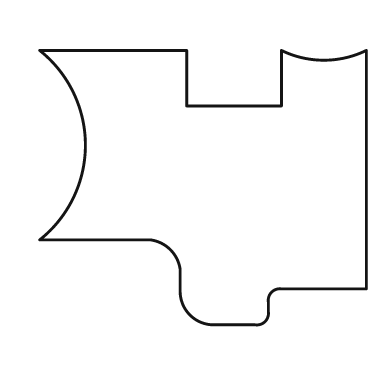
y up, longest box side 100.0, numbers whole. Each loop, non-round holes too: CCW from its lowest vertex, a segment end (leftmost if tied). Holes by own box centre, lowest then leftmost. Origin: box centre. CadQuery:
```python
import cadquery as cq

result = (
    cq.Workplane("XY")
    .moveTo(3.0, -42.0)
    .lineTo(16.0, -42.0)
    .threePointArc((19.0, -41.0), (20.0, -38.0))
    .lineTo(20.0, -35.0)
    .threePointArc((21.0, -32.0), (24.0, -31.0))
    .lineTo(50.0, -31.0)
    .lineTo(50.0, 42.0)
    .threePointArc((37.0, 39.0), (24.0, 42.0))
    .lineTo(24.0, 25.0)
    .lineTo(-5.0, 25.0)
    .lineTo(-5.0, 42.0)
    .lineTo(-50.0, 42.0)
    .threePointArc((-36.0, 13.0), (-50.0, -16.0))
    .lineTo(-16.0, -16.0)
    .threePointArc((-10.0, -19.0), (-7.0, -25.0))
    .lineTo(-7.0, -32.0)
    .threePointArc((-4.0, -39.0), (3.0, -42.0))
    .close()
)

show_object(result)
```